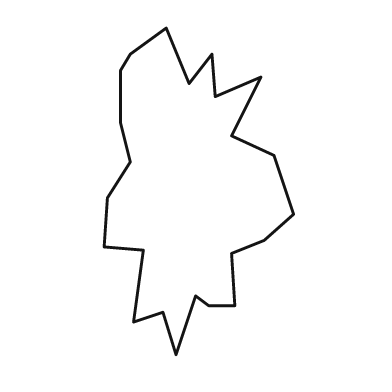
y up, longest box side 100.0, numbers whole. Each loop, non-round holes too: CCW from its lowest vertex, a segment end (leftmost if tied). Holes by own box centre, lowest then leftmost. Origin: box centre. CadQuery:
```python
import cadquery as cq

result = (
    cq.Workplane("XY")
    .moveTo(-7.0, -50.0)
    .lineTo(-1.0, -32.0)
    .lineTo(3.0, -35.0)
    .lineTo(11.0, -35.0)
    .lineTo(10.0, -19.0)
    .lineTo(20.0, -15.0)
    .lineTo(29.0, -7.0)
    .lineTo(23.0, 11.0)
    .lineTo(10.0, 17.0)
    .lineTo(19.0, 35.0)
    .lineTo(5.0, 29.0)
    .lineTo(4.0, 42.0)
    .lineTo(-3.0, 33.0)
    .lineTo(-10.0, 50.0)
    .lineTo(-21.0, 42.0)
    .lineTo(-24.0, 37.0)
    .lineTo(-24.0, 21.0)
    .lineTo(-21.0, 9.0)
    .lineTo(-28.0, -2.0)
    .lineTo(-29.0, -17.0)
    .lineTo(-17.0, -18.0)
    .lineTo(-20.0, -40.0)
    .lineTo(-11.0, -37.0)
    .close()
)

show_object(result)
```